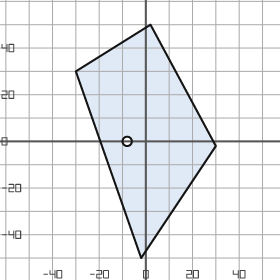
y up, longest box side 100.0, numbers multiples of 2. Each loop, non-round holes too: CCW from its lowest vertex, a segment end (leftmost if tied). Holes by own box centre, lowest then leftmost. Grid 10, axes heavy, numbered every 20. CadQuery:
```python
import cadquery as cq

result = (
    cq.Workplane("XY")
    .moveTo(-2.0, -50.0)
    .lineTo(30.0, -2.0)
    .lineTo(2.0, 50.0)
    .lineTo(-30.0, 30.0)
    .close()
    .moveTo(-8.0, 0.0)
    .circle(2.0)
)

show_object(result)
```